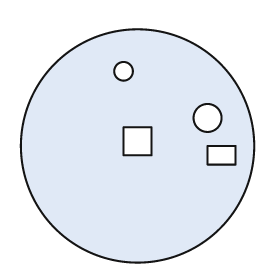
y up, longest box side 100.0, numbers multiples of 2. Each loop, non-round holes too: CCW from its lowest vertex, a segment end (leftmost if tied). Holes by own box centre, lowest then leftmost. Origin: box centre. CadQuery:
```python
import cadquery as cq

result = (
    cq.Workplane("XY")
    .moveTo(0.0, 0.0)
    .circle(50.0)
    .moveTo(30.0, -8.0)
    .lineTo(42.0, -8.0)
    .lineTo(42.0, 0.0)
    .lineTo(30.0, 0.0)
    .close()
    .moveTo(-6.0, -4.0)
    .lineTo(6.0, -4.0)
    .lineTo(6.0, 8.0)
    .lineTo(-6.0, 8.0)
    .close()
    .moveTo(30.0, 12.0)
    .circle(6.0)
    .moveTo(-6.0, 32.0)
    .circle(4.0)
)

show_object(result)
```